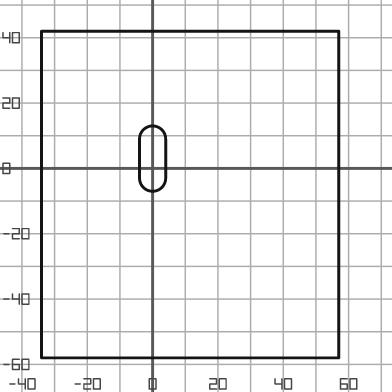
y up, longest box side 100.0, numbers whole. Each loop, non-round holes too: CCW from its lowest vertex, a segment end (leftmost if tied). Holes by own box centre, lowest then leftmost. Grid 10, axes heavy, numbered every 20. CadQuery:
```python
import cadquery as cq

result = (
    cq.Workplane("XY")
    .moveTo(-34.0, -58.0)
    .lineTo(57.0, -58.0)
    .lineTo(57.0, 42.0)
    .lineTo(-34.0, 42.0)
    .close()
    .moveTo(-4.0, -3.0)
    .threePointArc((0.0, -7.0), (4.0, -3.0))
    .lineTo(4.0, 9.0)
    .threePointArc((0.0, 13.0), (-4.0, 9.0))
    .close()
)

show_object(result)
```